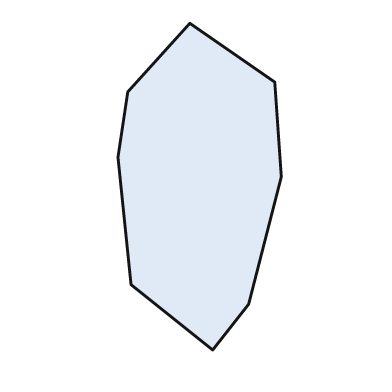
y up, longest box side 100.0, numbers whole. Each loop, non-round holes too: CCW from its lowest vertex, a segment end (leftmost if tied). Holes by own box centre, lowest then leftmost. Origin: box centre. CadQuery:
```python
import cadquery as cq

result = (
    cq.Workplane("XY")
    .moveTo(4.0, -50.0)
    .lineTo(15.0, -36.0)
    .lineTo(25.0, 3.0)
    .lineTo(23.0, 32.0)
    .lineTo(-3.0, 50.0)
    .lineTo(-22.0, 29.0)
    .lineTo(-25.0, 9.0)
    .lineTo(-21.0, -30.0)
    .close()
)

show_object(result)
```